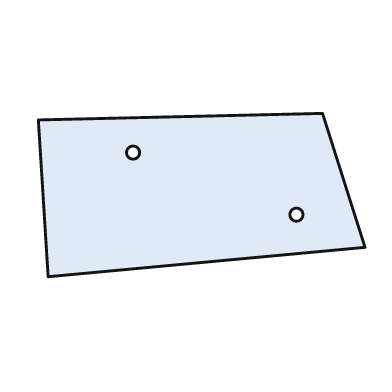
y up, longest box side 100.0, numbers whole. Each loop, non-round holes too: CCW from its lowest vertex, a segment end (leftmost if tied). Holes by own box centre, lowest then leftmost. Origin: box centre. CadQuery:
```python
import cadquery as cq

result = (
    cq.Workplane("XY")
    .moveTo(-47.0, -25.0)
    .lineTo(50.0, -16.0)
    .lineTo(37.0, 25.0)
    .lineTo(-50.0, 23.0)
    .close()
    .moveTo(29.0, -6.0)
    .circle(2.0)
    .moveTo(-21.0, 13.0)
    .circle(2.0)
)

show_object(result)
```